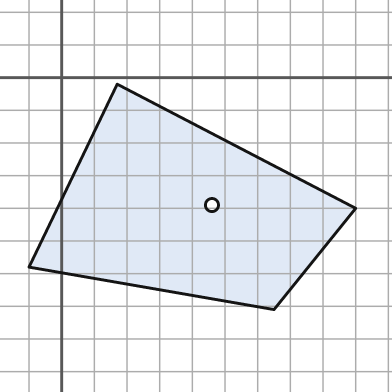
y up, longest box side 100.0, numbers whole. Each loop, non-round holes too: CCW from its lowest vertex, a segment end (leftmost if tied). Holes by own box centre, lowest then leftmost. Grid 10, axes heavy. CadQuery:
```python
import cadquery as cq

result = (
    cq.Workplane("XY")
    .moveTo(65.0, -71.0)
    .lineTo(90.0, -40.0)
    .lineTo(17.0, -2.0)
    .lineTo(-10.0, -58.0)
    .close()
    .moveTo(46.0, -39.0)
    .circle(2.0)
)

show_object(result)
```